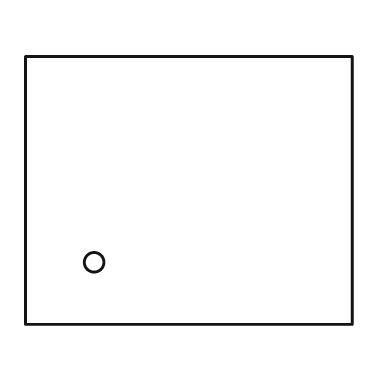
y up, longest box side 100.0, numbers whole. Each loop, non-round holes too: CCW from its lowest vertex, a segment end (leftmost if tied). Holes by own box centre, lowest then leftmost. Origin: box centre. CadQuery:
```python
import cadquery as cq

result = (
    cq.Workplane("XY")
    .moveTo(-50.0, -41.0)
    .lineTo(50.0, -41.0)
    .lineTo(50.0, 41.0)
    .lineTo(-50.0, 41.0)
    .close()
    .moveTo(-29.0, -22.0)
    .circle(3.0)
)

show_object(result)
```